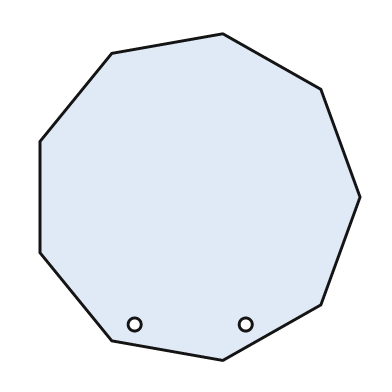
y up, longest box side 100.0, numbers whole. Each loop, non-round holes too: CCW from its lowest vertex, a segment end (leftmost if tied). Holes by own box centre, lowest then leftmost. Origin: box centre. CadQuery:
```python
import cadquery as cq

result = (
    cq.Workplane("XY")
    .moveTo(7.0, -50.0)
    .lineTo(37.0, -33.0)
    .lineTo(49.0, 0.0)
    .lineTo(37.0, 33.0)
    .lineTo(7.0, 50.0)
    .lineTo(-27.0, 44.0)
    .lineTo(-49.0, 17.0)
    .lineTo(-49.0, -17.0)
    .lineTo(-27.0, -44.0)
    .close()
    .moveTo(-20.0, -39.0)
    .circle(2.0)
    .moveTo(14.0, -39.0)
    .circle(2.0)
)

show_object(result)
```